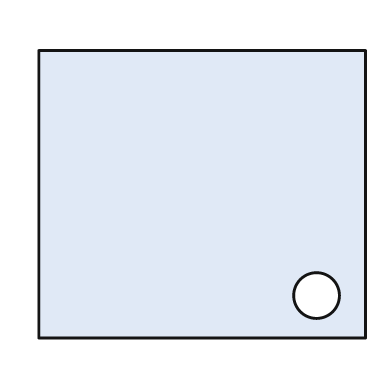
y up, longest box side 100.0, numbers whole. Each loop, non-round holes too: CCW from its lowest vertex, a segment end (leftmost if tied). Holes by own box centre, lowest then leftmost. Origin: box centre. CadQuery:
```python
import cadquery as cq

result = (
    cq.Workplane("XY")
    .moveTo(-50.0, -44.0)
    .lineTo(50.0, -44.0)
    .lineTo(50.0, 44.0)
    .lineTo(-50.0, 44.0)
    .close()
    .moveTo(35.0, -31.0)
    .circle(7.0)
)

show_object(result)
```